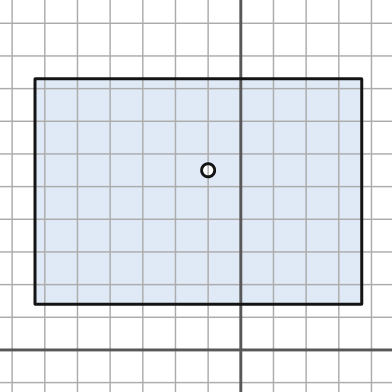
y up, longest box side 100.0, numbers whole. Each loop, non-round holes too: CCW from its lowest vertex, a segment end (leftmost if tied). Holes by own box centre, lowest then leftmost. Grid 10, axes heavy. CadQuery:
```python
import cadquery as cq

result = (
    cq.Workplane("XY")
    .moveTo(-63.0, 14.0)
    .lineTo(37.0, 14.0)
    .lineTo(37.0, 83.0)
    .lineTo(-63.0, 83.0)
    .close()
    .moveTo(-10.0, 55.0)
    .circle(2.0)
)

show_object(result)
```